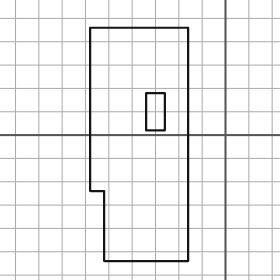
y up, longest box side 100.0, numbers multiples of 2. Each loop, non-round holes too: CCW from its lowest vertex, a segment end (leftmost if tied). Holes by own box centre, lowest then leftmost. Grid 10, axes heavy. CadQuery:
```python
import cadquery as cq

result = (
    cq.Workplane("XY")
    .moveTo(-52.0, -54.0)
    .lineTo(-16.0, -54.0)
    .lineTo(-16.0, 46.0)
    .lineTo(-58.0, 46.0)
    .lineTo(-58.0, -24.0)
    .lineTo(-52.0, -24.0)
    .close()
    .moveTo(-34.0, 2.0)
    .lineTo(-26.0, 2.0)
    .lineTo(-26.0, 18.0)
    .lineTo(-34.0, 18.0)
    .close()
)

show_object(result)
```